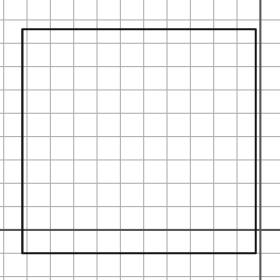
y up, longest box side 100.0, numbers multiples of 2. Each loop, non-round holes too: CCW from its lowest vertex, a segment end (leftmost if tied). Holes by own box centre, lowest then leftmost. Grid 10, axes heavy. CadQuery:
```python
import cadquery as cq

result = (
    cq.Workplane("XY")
    .moveTo(-102.0, -10.0)
    .lineTo(-2.0, -10.0)
    .lineTo(-2.0, 86.0)
    .lineTo(-102.0, 86.0)
    .close()
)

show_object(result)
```